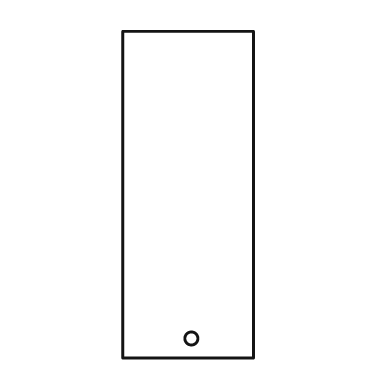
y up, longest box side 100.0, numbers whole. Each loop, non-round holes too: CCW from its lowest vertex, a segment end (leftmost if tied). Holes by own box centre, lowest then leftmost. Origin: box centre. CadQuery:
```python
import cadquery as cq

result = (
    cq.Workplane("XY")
    .moveTo(-20.0, -50.0)
    .lineTo(20.0, -50.0)
    .lineTo(20.0, 50.0)
    .lineTo(-20.0, 50.0)
    .close()
    .moveTo(1.0, -44.0)
    .circle(2.0)
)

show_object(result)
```